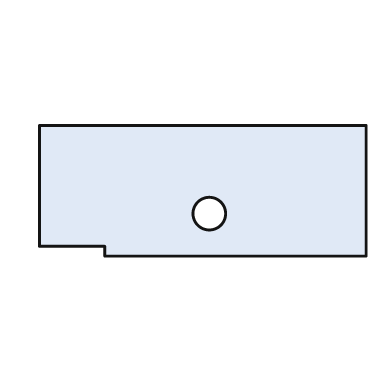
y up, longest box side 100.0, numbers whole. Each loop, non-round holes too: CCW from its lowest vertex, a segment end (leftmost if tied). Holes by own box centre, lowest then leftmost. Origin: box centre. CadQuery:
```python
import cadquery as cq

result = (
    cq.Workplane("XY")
    .moveTo(-30.0, -20.0)
    .lineTo(50.0, -20.0)
    .lineTo(50.0, 20.0)
    .lineTo(-50.0, 20.0)
    .lineTo(-50.0, -17.0)
    .lineTo(-30.0, -17.0)
    .close()
    .moveTo(2.0, -7.0)
    .circle(5.0)
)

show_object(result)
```